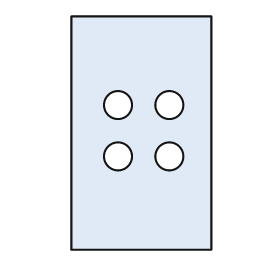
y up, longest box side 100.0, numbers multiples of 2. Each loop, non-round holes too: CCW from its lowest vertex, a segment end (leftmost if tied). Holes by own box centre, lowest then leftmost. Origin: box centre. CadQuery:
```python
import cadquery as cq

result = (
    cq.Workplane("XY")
    .moveTo(-30.0, -50.0)
    .lineTo(30.0, -50.0)
    .lineTo(30.0, 50.0)
    .lineTo(-30.0, 50.0)
    .close()
    .moveTo(-10.0, -10.0)
    .circle(6.0)
    .moveTo(12.0, -10.0)
    .circle(6.0)
    .moveTo(-10.0, 12.0)
    .circle(6.0)
    .moveTo(12.0, 12.0)
    .circle(6.0)
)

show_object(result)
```